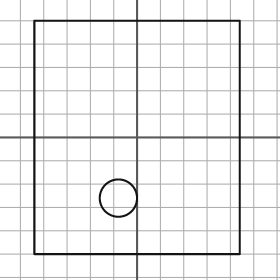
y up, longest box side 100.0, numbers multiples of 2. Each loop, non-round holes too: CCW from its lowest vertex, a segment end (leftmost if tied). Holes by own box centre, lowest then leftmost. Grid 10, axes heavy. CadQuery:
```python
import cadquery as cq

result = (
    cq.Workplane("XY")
    .moveTo(-44.0, -50.0)
    .lineTo(44.0, -50.0)
    .lineTo(44.0, 50.0)
    .lineTo(-44.0, 50.0)
    .close()
    .moveTo(-8.0, -26.0)
    .circle(8.0)
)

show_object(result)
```